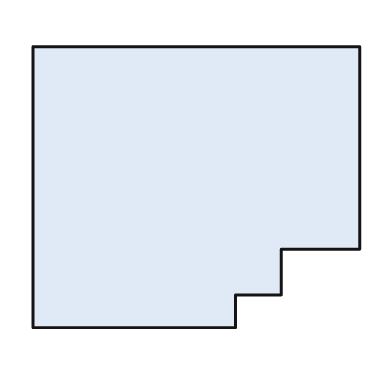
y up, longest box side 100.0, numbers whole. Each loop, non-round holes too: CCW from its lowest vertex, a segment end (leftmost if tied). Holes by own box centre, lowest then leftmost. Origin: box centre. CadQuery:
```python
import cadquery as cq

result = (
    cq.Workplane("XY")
    .moveTo(-50.0, -43.0)
    .lineTo(12.0, -43.0)
    .lineTo(12.0, -33.0)
    .lineTo(26.0, -33.0)
    .lineTo(26.0, -19.0)
    .lineTo(50.0, -19.0)
    .lineTo(50.0, 43.0)
    .lineTo(-50.0, 43.0)
    .close()
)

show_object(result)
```